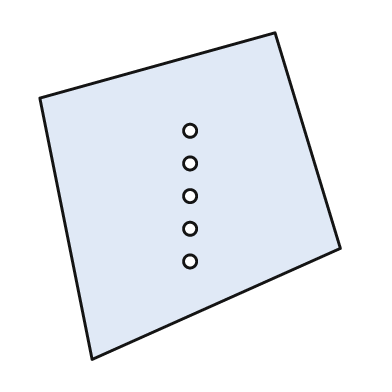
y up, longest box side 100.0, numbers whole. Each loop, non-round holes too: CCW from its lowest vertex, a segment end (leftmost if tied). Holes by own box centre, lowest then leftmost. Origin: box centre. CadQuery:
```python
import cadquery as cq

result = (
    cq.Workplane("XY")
    .moveTo(-30.0, -50.0)
    .lineTo(46.0, -16.0)
    .lineTo(26.0, 50.0)
    .lineTo(-46.0, 30.0)
    .close()
    .moveTo(0.0, -20.0)
    .circle(2.0)
    .moveTo(0.0, -10.0)
    .circle(2.0)
    .moveTo(0.0, 0.0)
    .circle(2.0)
    .moveTo(0.0, 10.0)
    .circle(2.0)
    .moveTo(0.0, 20.0)
    .circle(2.0)
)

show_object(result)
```